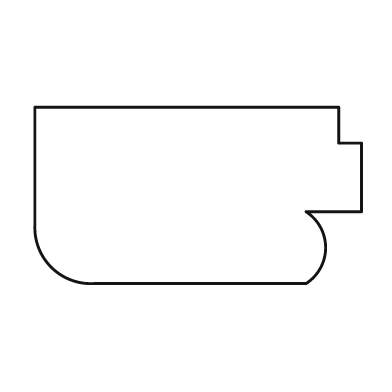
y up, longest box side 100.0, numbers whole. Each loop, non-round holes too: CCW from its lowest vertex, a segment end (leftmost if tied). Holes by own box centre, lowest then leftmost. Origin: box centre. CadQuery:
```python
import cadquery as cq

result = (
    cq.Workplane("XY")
    .moveTo(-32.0, -27.0)
    .lineTo(33.0, -27.0)
    .threePointArc((39.0, -16.0), (33.0, -5.0))
    .lineTo(50.0, -5.0)
    .lineTo(50.0, 16.0)
    .lineTo(43.0, 16.0)
    .lineTo(43.0, 27.0)
    .lineTo(-50.0, 27.0)
    .lineTo(-50.0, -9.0)
    .threePointArc((-45.0, -22.0), (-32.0, -27.0))
    .close()
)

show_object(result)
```